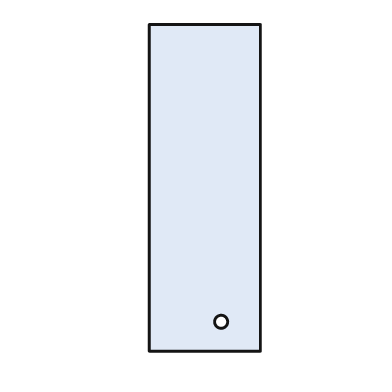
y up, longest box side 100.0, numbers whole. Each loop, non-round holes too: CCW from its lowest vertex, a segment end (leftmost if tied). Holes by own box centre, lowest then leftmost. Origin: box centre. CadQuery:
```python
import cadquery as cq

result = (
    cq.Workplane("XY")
    .moveTo(-17.0, -50.0)
    .lineTo(17.0, -50.0)
    .lineTo(17.0, 50.0)
    .lineTo(-17.0, 50.0)
    .close()
    .moveTo(5.0, -41.0)
    .circle(2.0)
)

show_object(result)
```